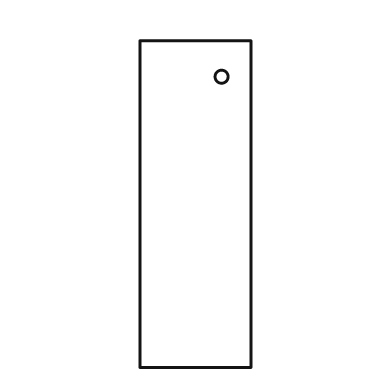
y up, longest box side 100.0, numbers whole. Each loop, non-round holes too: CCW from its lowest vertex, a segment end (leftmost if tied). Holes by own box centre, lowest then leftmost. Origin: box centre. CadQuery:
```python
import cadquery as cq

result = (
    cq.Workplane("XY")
    .moveTo(-17.0, -50.0)
    .lineTo(17.0, -50.0)
    .lineTo(17.0, 50.0)
    .lineTo(-17.0, 50.0)
    .close()
    .moveTo(8.0, 39.0)
    .circle(2.0)
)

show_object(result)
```